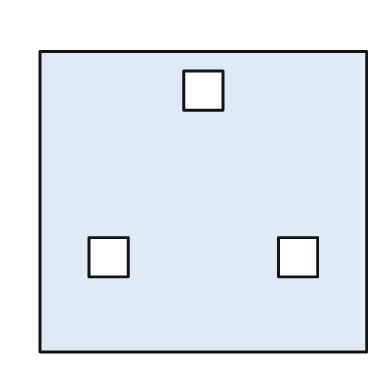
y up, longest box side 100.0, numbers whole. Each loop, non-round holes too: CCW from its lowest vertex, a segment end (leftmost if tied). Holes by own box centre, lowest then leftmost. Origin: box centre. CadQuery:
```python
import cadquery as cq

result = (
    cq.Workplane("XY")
    .moveTo(-50.0, -46.0)
    .lineTo(50.0, -46.0)
    .lineTo(50.0, 46.0)
    .lineTo(-50.0, 46.0)
    .close()
    .moveTo(-35.0, -23.0)
    .lineTo(-23.0, -23.0)
    .lineTo(-23.0, -11.0)
    .lineTo(-35.0, -11.0)
    .close()
    .moveTo(23.0, -23.0)
    .lineTo(35.0, -23.0)
    .lineTo(35.0, -11.0)
    .lineTo(23.0, -11.0)
    .close()
    .moveTo(-6.0, 28.0)
    .lineTo(6.0, 28.0)
    .lineTo(6.0, 40.0)
    .lineTo(-6.0, 40.0)
    .close()
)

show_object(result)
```